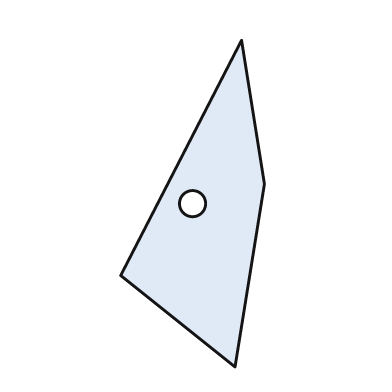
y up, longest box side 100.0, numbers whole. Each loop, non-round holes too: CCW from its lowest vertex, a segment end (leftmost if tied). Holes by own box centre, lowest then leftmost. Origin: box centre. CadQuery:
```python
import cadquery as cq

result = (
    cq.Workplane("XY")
    .moveTo(13.0, -50.0)
    .lineTo(22.0, 6.0)
    .lineTo(15.0, 50.0)
    .lineTo(-22.0, -22.0)
    .close()
    .moveTo(0.0, 0.0)
    .circle(4.0)
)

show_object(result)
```